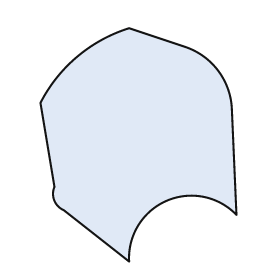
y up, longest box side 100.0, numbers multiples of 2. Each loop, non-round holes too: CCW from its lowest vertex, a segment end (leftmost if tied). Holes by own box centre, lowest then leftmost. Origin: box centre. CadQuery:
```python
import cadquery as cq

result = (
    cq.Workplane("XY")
    .moveTo(-4.0, -50.0)
    .threePointArc((12.0, -24.0), (42.0, -30.0))
    .lineTo(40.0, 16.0)
    .threePointArc((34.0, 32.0), (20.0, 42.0))
    .lineTo(-4.0, 50.0)
    .threePointArc((-26.0, 38.0), (-42.0, 18.0))
    .lineTo(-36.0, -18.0)
    .threePointArc((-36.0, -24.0), (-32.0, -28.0))
    .close()
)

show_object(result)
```